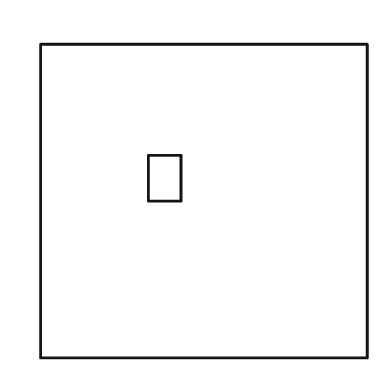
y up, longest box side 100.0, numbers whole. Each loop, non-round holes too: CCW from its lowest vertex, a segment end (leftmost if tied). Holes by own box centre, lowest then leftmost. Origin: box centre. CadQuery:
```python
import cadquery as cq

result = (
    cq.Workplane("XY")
    .moveTo(-50.0, -48.0)
    .lineTo(50.0, -48.0)
    .lineTo(50.0, 48.0)
    .lineTo(-50.0, 48.0)
    .close()
    .moveTo(-17.0, 0.0)
    .lineTo(-7.0, 0.0)
    .lineTo(-7.0, 14.0)
    .lineTo(-17.0, 14.0)
    .close()
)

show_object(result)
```